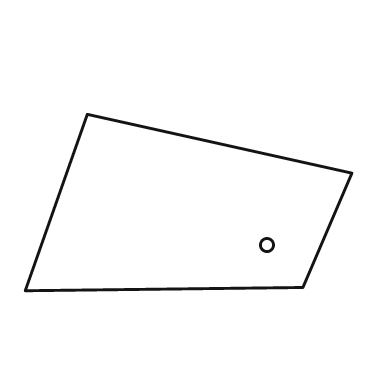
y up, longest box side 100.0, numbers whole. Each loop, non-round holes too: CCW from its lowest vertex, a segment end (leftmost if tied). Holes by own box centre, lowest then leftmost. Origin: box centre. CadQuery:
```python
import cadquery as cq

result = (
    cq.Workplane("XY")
    .moveTo(-50.0, -27.0)
    .lineTo(35.0, -26.0)
    .lineTo(50.0, 9.0)
    .lineTo(-31.0, 27.0)
    .close()
    .moveTo(24.0, -13.0)
    .circle(2.0)
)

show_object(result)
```